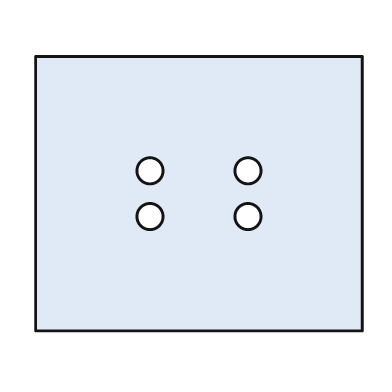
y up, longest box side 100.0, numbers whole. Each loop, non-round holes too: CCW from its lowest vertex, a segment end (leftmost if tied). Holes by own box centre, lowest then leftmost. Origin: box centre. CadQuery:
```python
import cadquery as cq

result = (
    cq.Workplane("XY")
    .moveTo(-50.0, -42.0)
    .lineTo(50.0, -42.0)
    .lineTo(50.0, 42.0)
    .lineTo(-50.0, 42.0)
    .close()
    .moveTo(-15.0, -7.0)
    .circle(4.0)
    .moveTo(15.0, -7.0)
    .circle(4.0)
    .moveTo(-15.0, 7.0)
    .circle(4.0)
    .moveTo(15.0, 7.0)
    .circle(4.0)
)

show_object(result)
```